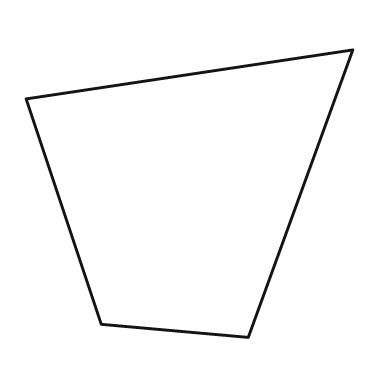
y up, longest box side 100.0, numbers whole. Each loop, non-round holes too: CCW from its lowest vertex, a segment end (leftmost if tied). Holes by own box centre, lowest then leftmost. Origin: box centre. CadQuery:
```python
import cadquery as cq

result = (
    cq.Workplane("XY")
    .moveTo(18.0, -44.0)
    .lineTo(50.0, 44.0)
    .lineTo(-50.0, 29.0)
    .lineTo(-27.0, -40.0)
    .close()
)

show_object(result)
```